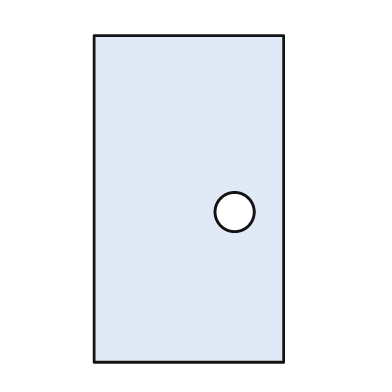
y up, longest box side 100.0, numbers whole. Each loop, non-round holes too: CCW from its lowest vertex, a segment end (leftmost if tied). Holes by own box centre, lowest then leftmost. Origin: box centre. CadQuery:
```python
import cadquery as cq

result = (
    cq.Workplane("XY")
    .moveTo(-29.0, -50.0)
    .lineTo(29.0, -50.0)
    .lineTo(29.0, 50.0)
    .lineTo(-29.0, 50.0)
    .close()
    .moveTo(14.0, -4.0)
    .circle(6.0)
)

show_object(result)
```